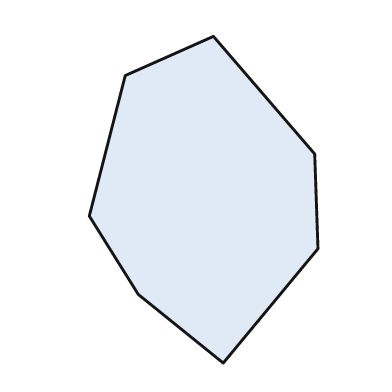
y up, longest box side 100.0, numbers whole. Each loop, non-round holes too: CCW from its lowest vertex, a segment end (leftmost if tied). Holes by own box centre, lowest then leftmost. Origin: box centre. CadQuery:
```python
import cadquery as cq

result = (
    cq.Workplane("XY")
    .moveTo(6.0, -50.0)
    .lineTo(35.0, -15.0)
    .lineTo(34.0, 14.0)
    .lineTo(3.0, 50.0)
    .lineTo(-24.0, 38.0)
    .lineTo(-35.0, -5.0)
    .lineTo(-20.0, -29.0)
    .close()
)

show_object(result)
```